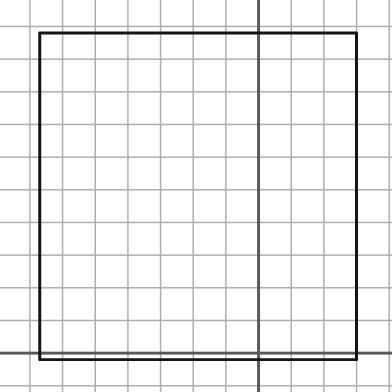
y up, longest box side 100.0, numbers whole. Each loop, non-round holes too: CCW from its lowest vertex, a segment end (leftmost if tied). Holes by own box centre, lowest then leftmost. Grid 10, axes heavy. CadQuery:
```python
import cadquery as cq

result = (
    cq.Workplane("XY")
    .moveTo(-67.0, -2.0)
    .lineTo(30.0, -2.0)
    .lineTo(30.0, 98.0)
    .lineTo(-67.0, 98.0)
    .close()
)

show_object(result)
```